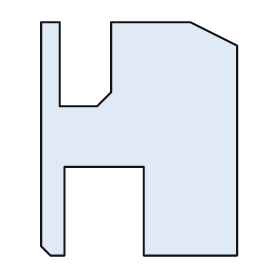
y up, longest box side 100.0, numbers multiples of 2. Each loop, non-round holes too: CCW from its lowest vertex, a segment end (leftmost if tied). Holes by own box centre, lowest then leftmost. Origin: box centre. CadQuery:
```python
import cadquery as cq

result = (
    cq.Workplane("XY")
    .moveTo(-38.0, -50.0)
    .lineTo(-32.0, -50.0)
    .lineTo(-32.0, -12.0)
    .lineTo(2.0, -12.0)
    .lineTo(2.0, -50.0)
    .lineTo(42.0, -50.0)
    .lineTo(42.0, 40.0)
    .lineTo(22.0, 50.0)
    .lineTo(-12.0, 50.0)
    .lineTo(-12.0, 20.0)
    .lineTo(-18.0, 14.0)
    .lineTo(-34.0, 14.0)
    .lineTo(-34.0, 50.0)
    .lineTo(-42.0, 50.0)
    .lineTo(-42.0, -46.0)
    .close()
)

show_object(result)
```